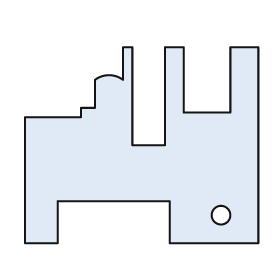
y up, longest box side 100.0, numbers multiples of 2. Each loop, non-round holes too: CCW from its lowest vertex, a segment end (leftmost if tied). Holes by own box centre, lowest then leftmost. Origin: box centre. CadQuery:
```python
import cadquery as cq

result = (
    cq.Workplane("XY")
    .moveTo(-50.0, -42.0)
    .lineTo(-36.0, -42.0)
    .lineTo(-36.0, -24.0)
    .lineTo(12.0, -24.0)
    .lineTo(12.0, -42.0)
    .lineTo(50.0, -42.0)
    .lineTo(50.0, 42.0)
    .lineTo(38.0, 42.0)
    .lineTo(38.0, 14.0)
    .lineTo(18.0, 14.0)
    .lineTo(18.0, 42.0)
    .lineTo(10.0, 42.0)
    .lineTo(10.0, 0.0)
    .lineTo(-4.0, 0.0)
    .lineTo(-4.0, 42.0)
    .lineTo(-8.0, 42.0)
    .lineTo(-8.0, 28.0)
    .threePointArc((-14.0, 30.0), (-20.0, 28.0))
    .lineTo(-20.0, 16.0)
    .lineTo(-26.0, 16.0)
    .lineTo(-26.0, 12.0)
    .lineTo(-50.0, 12.0)
    .close()
    .moveTo(34.0, -30.0)
    .circle(4.0)
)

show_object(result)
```